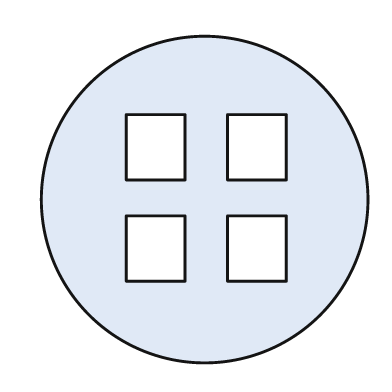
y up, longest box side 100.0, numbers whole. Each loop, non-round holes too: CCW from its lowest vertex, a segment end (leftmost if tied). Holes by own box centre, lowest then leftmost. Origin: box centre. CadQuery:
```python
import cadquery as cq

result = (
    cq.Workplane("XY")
    .moveTo(0.0, 0.0)
    .circle(50.0)
    .moveTo(-24.0, -25.0)
    .lineTo(-6.0, -25.0)
    .lineTo(-6.0, -5.0)
    .lineTo(-24.0, -5.0)
    .close()
    .moveTo(7.0, -25.0)
    .lineTo(25.0, -25.0)
    .lineTo(25.0, -5.0)
    .lineTo(7.0, -5.0)
    .close()
    .moveTo(-24.0, 6.0)
    .lineTo(-6.0, 6.0)
    .lineTo(-6.0, 26.0)
    .lineTo(-24.0, 26.0)
    .close()
    .moveTo(7.0, 6.0)
    .lineTo(25.0, 6.0)
    .lineTo(25.0, 26.0)
    .lineTo(7.0, 26.0)
    .close()
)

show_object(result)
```